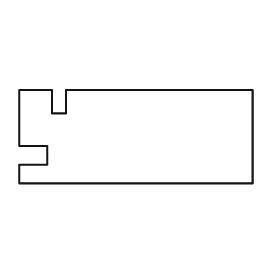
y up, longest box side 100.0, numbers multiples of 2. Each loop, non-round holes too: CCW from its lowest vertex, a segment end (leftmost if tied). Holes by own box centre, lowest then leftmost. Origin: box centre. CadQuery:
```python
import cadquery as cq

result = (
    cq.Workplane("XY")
    .moveTo(-50.0, -20.0)
    .lineTo(50.0, -20.0)
    .lineTo(50.0, 20.0)
    .lineTo(-30.0, 20.0)
    .lineTo(-30.0, 10.0)
    .lineTo(-36.0, 10.0)
    .lineTo(-36.0, 20.0)
    .lineTo(-50.0, 20.0)
    .lineTo(-50.0, -4.0)
    .lineTo(-38.0, -4.0)
    .lineTo(-38.0, -12.0)
    .lineTo(-50.0, -12.0)
    .close()
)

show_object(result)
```